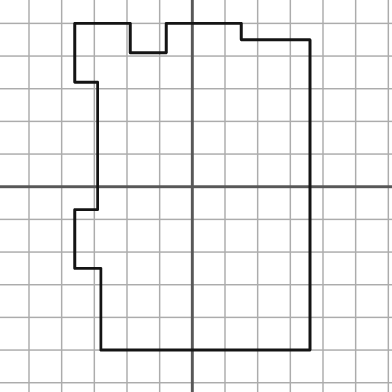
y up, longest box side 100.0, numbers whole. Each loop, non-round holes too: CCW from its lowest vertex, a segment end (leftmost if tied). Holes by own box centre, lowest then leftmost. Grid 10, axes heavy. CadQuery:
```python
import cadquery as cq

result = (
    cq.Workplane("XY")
    .moveTo(-28.0, -50.0)
    .lineTo(36.0, -50.0)
    .lineTo(36.0, 45.0)
    .lineTo(15.0, 45.0)
    .lineTo(15.0, 50.0)
    .lineTo(-8.0, 50.0)
    .lineTo(-8.0, 41.0)
    .lineTo(-19.0, 41.0)
    .lineTo(-19.0, 50.0)
    .lineTo(-36.0, 50.0)
    .lineTo(-36.0, 32.0)
    .lineTo(-29.0, 32.0)
    .lineTo(-29.0, -7.0)
    .lineTo(-36.0, -7.0)
    .lineTo(-36.0, -25.0)
    .lineTo(-28.0, -25.0)
    .close()
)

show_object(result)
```